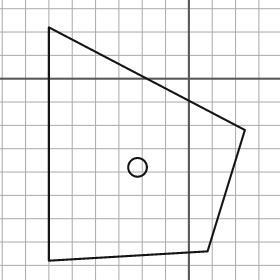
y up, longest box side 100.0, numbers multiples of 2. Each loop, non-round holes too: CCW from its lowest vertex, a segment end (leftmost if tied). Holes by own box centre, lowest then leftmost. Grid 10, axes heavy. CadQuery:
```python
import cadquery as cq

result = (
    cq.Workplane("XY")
    .moveTo(-60.0, -78.0)
    .lineTo(8.0, -74.0)
    .lineTo(24.0, -22.0)
    .lineTo(-60.0, 22.0)
    .close()
    .moveTo(-22.0, -38.0)
    .circle(4.0)
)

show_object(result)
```